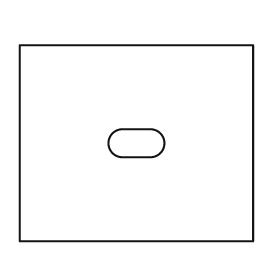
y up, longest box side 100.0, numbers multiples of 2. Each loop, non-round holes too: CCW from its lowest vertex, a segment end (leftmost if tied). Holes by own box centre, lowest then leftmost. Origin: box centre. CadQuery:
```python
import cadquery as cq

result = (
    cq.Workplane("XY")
    .moveTo(-50.0, -42.0)
    .lineTo(50.0, -42.0)
    .lineTo(50.0, 42.0)
    .lineTo(-50.0, 42.0)
    .close()
    .moveTo(-6.0, -6.0)
    .lineTo(6.0, -6.0)
    .threePointArc((12.0, 0.0), (6.0, 6.0))
    .lineTo(-6.0, 6.0)
    .threePointArc((-12.0, 0.0), (-6.0, -6.0))
    .close()
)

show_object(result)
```